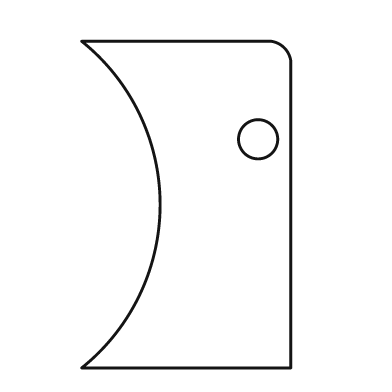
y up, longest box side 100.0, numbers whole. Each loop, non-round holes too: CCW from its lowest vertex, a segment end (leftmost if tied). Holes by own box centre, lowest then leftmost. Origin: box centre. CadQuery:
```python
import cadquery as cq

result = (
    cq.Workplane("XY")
    .moveTo(-32.0, -50.0)
    .lineTo(32.0, -50.0)
    .lineTo(32.0, 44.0)
    .threePointArc((30.0, 48.0), (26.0, 50.0))
    .lineTo(-32.0, 50.0)
    .threePointArc((-8.0, 0.0), (-32.0, -50.0))
    .close()
    .moveTo(22.0, 20.0)
    .circle(6.0)
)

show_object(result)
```